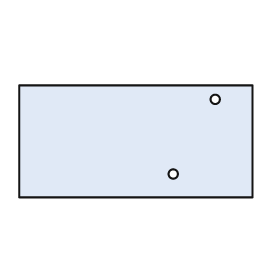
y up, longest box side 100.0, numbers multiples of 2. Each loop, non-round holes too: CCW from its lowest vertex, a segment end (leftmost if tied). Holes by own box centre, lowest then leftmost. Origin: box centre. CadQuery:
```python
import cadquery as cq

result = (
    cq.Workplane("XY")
    .moveTo(-50.0, -24.0)
    .lineTo(50.0, -24.0)
    .lineTo(50.0, 24.0)
    .lineTo(-50.0, 24.0)
    .close()
    .moveTo(16.0, -14.0)
    .circle(2.0)
    .moveTo(34.0, 18.0)
    .circle(2.0)
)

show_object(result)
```